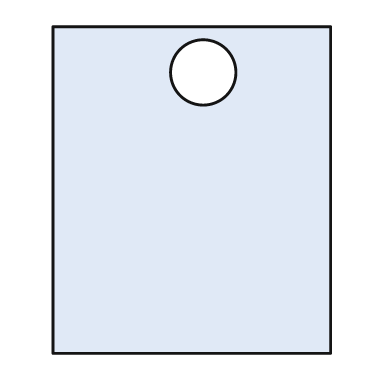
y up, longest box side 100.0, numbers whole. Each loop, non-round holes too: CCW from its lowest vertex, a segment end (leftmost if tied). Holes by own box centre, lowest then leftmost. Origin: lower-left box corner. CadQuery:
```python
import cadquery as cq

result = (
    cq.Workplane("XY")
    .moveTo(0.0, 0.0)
    .lineTo(85.0, 0.0)
    .lineTo(85.0, 100.0)
    .lineTo(0.0, 100.0)
    .close()
    .moveTo(46.0, 86.0)
    .circle(10.0)
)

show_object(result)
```